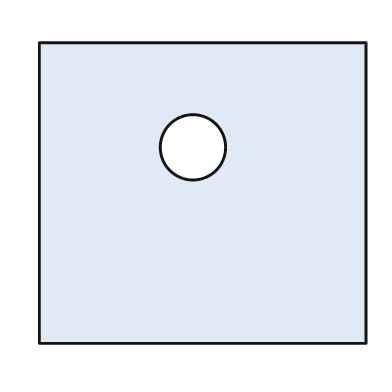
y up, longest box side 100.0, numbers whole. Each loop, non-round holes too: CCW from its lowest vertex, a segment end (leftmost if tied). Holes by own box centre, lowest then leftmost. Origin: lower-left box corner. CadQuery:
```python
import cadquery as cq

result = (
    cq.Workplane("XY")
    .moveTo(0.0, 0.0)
    .lineTo(100.0, 0.0)
    .lineTo(100.0, 92.0)
    .lineTo(0.0, 92.0)
    .close()
    .moveTo(47.0, 60.0)
    .circle(10.0)
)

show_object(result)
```